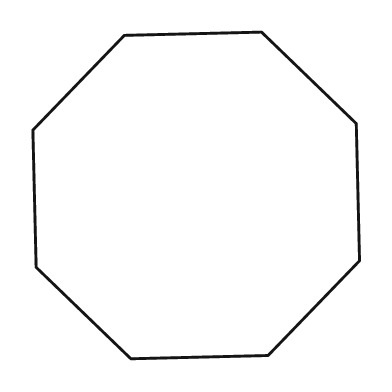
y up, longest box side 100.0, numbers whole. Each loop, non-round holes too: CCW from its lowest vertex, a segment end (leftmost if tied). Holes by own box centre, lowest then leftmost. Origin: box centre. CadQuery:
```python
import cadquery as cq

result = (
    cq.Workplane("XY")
    .moveTo(-20.0, -50.0)
    .lineTo(22.0, -49.0)
    .lineTo(50.0, -20.0)
    .lineTo(49.0, 22.0)
    .lineTo(20.0, 50.0)
    .lineTo(-22.0, 49.0)
    .lineTo(-50.0, 20.0)
    .lineTo(-49.0, -22.0)
    .close()
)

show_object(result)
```